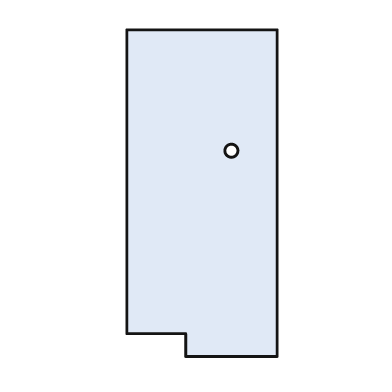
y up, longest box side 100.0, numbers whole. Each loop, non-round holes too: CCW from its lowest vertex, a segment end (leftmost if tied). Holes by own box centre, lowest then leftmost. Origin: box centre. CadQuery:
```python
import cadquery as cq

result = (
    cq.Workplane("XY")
    .moveTo(-5.0, -50.0)
    .lineTo(23.0, -50.0)
    .lineTo(23.0, 50.0)
    .lineTo(-23.0, 50.0)
    .lineTo(-23.0, -43.0)
    .lineTo(-5.0, -43.0)
    .close()
    .moveTo(9.0, 13.0)
    .circle(2.0)
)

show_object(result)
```